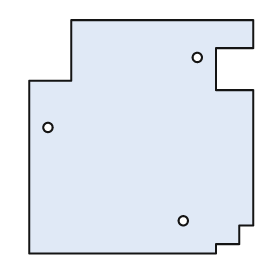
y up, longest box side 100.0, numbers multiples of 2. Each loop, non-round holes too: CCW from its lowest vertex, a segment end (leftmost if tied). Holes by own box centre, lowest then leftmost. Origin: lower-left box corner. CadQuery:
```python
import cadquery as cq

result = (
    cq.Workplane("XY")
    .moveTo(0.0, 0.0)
    .lineTo(80.0, 0.0)
    .lineTo(80.0, 4.0)
    .lineTo(90.0, 4.0)
    .lineTo(90.0, 12.0)
    .lineTo(96.0, 12.0)
    .lineTo(96.0, 70.0)
    .lineTo(80.0, 70.0)
    .lineTo(80.0, 88.0)
    .lineTo(96.0, 88.0)
    .lineTo(96.0, 100.0)
    .lineTo(18.0, 100.0)
    .lineTo(18.0, 74.0)
    .lineTo(0.0, 74.0)
    .close()
    .moveTo(66.0, 14.0)
    .circle(2.0)
    .moveTo(8.0, 54.0)
    .circle(2.0)
    .moveTo(72.0, 84.0)
    .circle(2.0)
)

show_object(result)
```